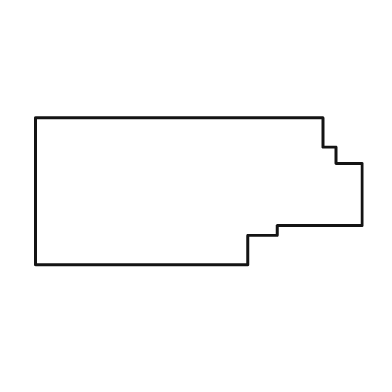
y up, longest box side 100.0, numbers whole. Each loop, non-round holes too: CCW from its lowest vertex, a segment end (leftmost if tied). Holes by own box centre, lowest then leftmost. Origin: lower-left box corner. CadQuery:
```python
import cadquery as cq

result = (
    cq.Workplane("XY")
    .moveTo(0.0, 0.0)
    .lineTo(65.0, 0.0)
    .lineTo(65.0, 9.0)
    .lineTo(74.0, 9.0)
    .lineTo(74.0, 12.0)
    .lineTo(100.0, 12.0)
    .lineTo(100.0, 31.0)
    .lineTo(92.0, 31.0)
    .lineTo(92.0, 36.0)
    .lineTo(88.0, 36.0)
    .lineTo(88.0, 45.0)
    .lineTo(0.0, 45.0)
    .close()
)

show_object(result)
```